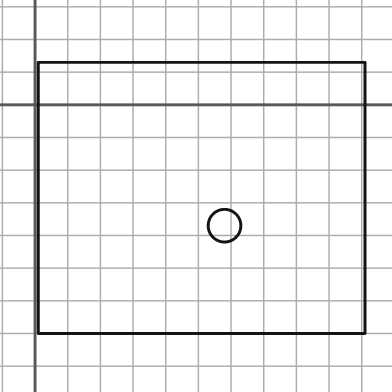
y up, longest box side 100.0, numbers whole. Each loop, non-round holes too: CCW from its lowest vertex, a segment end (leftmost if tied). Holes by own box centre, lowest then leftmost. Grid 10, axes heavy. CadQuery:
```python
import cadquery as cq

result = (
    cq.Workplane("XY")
    .moveTo(1.0, -70.0)
    .lineTo(101.0, -70.0)
    .lineTo(101.0, 13.0)
    .lineTo(1.0, 13.0)
    .close()
    .moveTo(58.0, -37.0)
    .circle(5.0)
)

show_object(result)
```